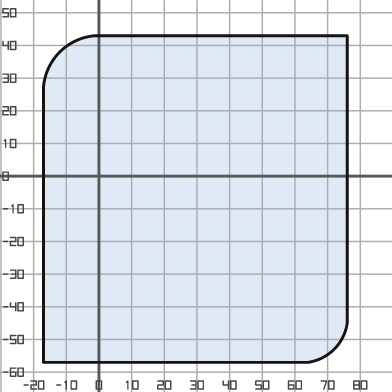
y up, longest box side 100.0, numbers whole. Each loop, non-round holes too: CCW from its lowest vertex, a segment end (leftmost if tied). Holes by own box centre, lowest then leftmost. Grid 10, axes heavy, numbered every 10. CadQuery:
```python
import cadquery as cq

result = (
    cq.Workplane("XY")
    .moveTo(-17.0, -57.0)
    .lineTo(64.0, -57.0)
    .threePointArc((72.0, -53.0), (76.0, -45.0))
    .lineTo(76.0, 43.0)
    .lineTo(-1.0, 43.0)
    .threePointArc((-12.0, 38.0), (-17.0, 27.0))
    .close()
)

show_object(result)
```